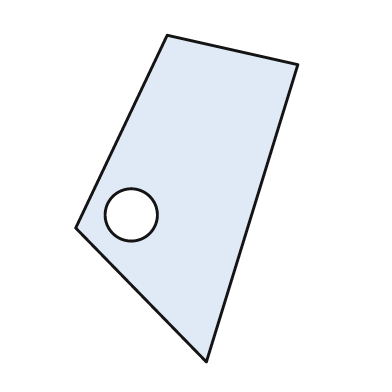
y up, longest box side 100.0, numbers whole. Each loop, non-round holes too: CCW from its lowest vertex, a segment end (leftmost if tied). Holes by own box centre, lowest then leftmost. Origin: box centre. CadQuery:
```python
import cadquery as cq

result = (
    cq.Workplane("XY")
    .moveTo(6.0, -50.0)
    .lineTo(34.0, 41.0)
    .lineTo(-6.0, 50.0)
    .lineTo(-34.0, -9.0)
    .close()
    .moveTo(-17.0, -5.0)
    .circle(8.0)
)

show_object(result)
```